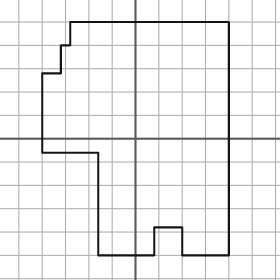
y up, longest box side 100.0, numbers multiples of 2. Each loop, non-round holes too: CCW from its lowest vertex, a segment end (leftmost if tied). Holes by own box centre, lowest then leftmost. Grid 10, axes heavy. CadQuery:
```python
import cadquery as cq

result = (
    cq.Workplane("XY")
    .moveTo(-16.0, -50.0)
    .lineTo(8.0, -50.0)
    .lineTo(8.0, -38.0)
    .lineTo(20.0, -38.0)
    .lineTo(20.0, -50.0)
    .lineTo(40.0, -50.0)
    .lineTo(40.0, 50.0)
    .lineTo(-28.0, 50.0)
    .lineTo(-28.0, 40.0)
    .lineTo(-32.0, 40.0)
    .lineTo(-32.0, 28.0)
    .lineTo(-40.0, 28.0)
    .lineTo(-40.0, -6.0)
    .lineTo(-16.0, -6.0)
    .close()
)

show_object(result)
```